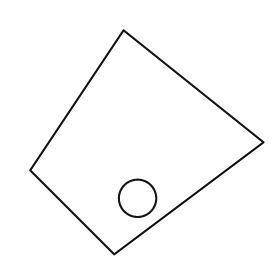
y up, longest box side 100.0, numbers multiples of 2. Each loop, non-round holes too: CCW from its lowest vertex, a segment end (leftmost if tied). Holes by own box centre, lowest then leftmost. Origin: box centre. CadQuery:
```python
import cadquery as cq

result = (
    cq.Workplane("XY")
    .moveTo(-14.0, -48.0)
    .lineTo(50.0, 0.0)
    .lineTo(-10.0, 48.0)
    .lineTo(-50.0, -12.0)
    .close()
    .moveTo(-4.0, -24.0)
    .circle(8.0)
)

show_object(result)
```